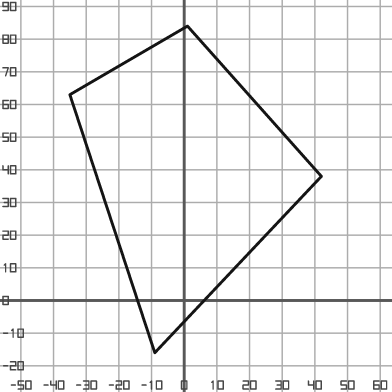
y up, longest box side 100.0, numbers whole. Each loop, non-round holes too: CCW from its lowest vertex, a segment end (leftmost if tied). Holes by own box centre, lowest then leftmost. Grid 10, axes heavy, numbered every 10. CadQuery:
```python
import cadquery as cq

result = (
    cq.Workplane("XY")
    .moveTo(-9.0, -16.0)
    .lineTo(42.0, 38.0)
    .lineTo(1.0, 84.0)
    .lineTo(-35.0, 63.0)
    .close()
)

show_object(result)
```